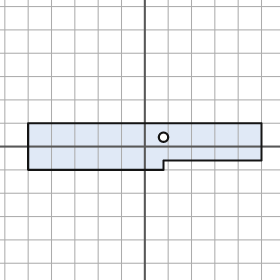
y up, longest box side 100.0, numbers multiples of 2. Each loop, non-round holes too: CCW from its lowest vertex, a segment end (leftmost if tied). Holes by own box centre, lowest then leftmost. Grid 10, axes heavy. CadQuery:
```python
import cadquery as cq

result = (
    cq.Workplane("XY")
    .moveTo(-50.0, -10.0)
    .lineTo(8.0, -10.0)
    .lineTo(8.0, -6.0)
    .lineTo(50.0, -6.0)
    .lineTo(50.0, 10.0)
    .lineTo(-50.0, 10.0)
    .close()
    .moveTo(8.0, 4.0)
    .circle(2.0)
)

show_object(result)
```